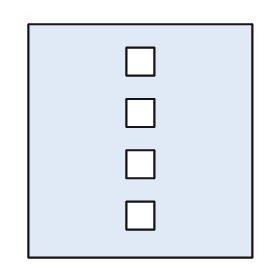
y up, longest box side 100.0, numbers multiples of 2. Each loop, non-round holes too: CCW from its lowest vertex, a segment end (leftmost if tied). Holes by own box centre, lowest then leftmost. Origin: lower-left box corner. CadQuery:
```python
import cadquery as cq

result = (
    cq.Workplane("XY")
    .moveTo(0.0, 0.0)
    .lineTo(96.0, 0.0)
    .lineTo(96.0, 100.0)
    .lineTo(0.0, 100.0)
    .close()
    .moveTo(42.0, 12.0)
    .lineTo(54.0, 12.0)
    .lineTo(54.0, 24.0)
    .lineTo(42.0, 24.0)
    .close()
    .moveTo(42.0, 34.0)
    .lineTo(54.0, 34.0)
    .lineTo(54.0, 46.0)
    .lineTo(42.0, 46.0)
    .close()
    .moveTo(42.0, 56.0)
    .lineTo(54.0, 56.0)
    .lineTo(54.0, 68.0)
    .lineTo(42.0, 68.0)
    .close()
    .moveTo(42.0, 78.0)
    .lineTo(54.0, 78.0)
    .lineTo(54.0, 90.0)
    .lineTo(42.0, 90.0)
    .close()
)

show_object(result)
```